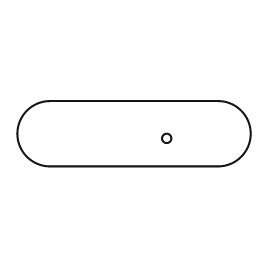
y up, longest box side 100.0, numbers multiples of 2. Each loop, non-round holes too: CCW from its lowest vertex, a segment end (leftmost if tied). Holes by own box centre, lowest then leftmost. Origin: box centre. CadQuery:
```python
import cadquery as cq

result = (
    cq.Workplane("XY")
    .moveTo(-36.0, -14.0)
    .lineTo(36.0, -14.0)
    .threePointArc((50.0, 0.0), (36.0, 14.0))
    .lineTo(-36.0, 14.0)
    .threePointArc((-50.0, 0.0), (-36.0, -14.0))
    .close()
    .moveTo(14.0, -2.0)
    .circle(2.0)
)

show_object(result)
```